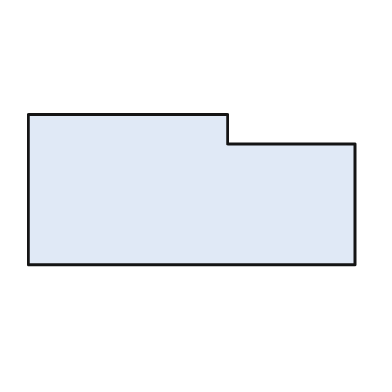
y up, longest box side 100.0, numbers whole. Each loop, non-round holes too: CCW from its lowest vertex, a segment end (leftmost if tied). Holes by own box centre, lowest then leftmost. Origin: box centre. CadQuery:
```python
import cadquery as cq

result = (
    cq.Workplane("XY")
    .moveTo(-50.0, -23.0)
    .lineTo(50.0, -23.0)
    .lineTo(50.0, 14.0)
    .lineTo(11.0, 14.0)
    .lineTo(11.0, 23.0)
    .lineTo(-50.0, 23.0)
    .close()
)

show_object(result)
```